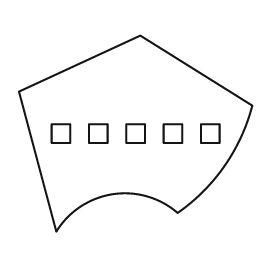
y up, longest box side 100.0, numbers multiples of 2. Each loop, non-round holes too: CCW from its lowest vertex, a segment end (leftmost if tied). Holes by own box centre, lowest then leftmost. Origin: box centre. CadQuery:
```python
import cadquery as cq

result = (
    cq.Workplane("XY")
    .moveTo(-34.0, -42.0)
    .threePointArc((-10.0, -26.0), (18.0, -34.0))
    .threePointArc((38.0, -14.0), (50.0, 12.0))
    .lineTo(2.0, 42.0)
    .lineTo(-50.0, 18.0)
    .close()
    .moveTo(-36.0, -4.0)
    .lineTo(-28.0, -4.0)
    .lineTo(-28.0, 4.0)
    .lineTo(-36.0, 4.0)
    .close()
    .moveTo(-20.0, -4.0)
    .lineTo(-12.0, -4.0)
    .lineTo(-12.0, 4.0)
    .lineTo(-20.0, 4.0)
    .close()
    .moveTo(-4.0, -4.0)
    .lineTo(4.0, -4.0)
    .lineTo(4.0, 4.0)
    .lineTo(-4.0, 4.0)
    .close()
    .moveTo(12.0, -4.0)
    .lineTo(20.0, -4.0)
    .lineTo(20.0, 4.0)
    .lineTo(12.0, 4.0)
    .close()
    .moveTo(28.0, -4.0)
    .lineTo(36.0, -4.0)
    .lineTo(36.0, 4.0)
    .lineTo(28.0, 4.0)
    .close()
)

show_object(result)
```